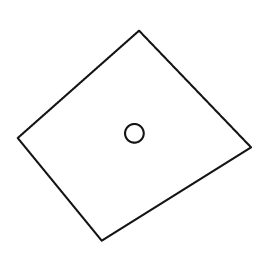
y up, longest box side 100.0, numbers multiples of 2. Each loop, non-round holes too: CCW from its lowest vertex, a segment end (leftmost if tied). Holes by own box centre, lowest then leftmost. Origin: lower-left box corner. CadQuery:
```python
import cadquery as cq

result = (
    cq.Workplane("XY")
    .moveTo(36.0, 0.0)
    .lineTo(100.0, 40.0)
    .lineTo(52.0, 90.0)
    .lineTo(0.0, 44.0)
    .close()
    .moveTo(50.0, 46.0)
    .circle(4.0)
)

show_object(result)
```